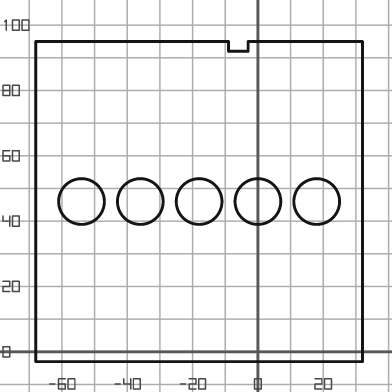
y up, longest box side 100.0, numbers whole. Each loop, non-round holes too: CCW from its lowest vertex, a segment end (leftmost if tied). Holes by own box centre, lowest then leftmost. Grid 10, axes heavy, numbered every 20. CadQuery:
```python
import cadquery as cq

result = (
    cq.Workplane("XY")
    .moveTo(-68.0, -3.0)
    .lineTo(32.0, -3.0)
    .lineTo(32.0, 95.0)
    .lineTo(-3.0, 95.0)
    .lineTo(-3.0, 92.0)
    .lineTo(-9.0, 92.0)
    .lineTo(-9.0, 95.0)
    .lineTo(-68.0, 95.0)
    .close()
    .moveTo(-54.0, 46.0)
    .circle(7.0)
    .moveTo(-36.0, 46.0)
    .circle(7.0)
    .moveTo(-18.0, 46.0)
    .circle(7.0)
    .moveTo(0.0, 46.0)
    .circle(7.0)
    .moveTo(18.0, 46.0)
    .circle(7.0)
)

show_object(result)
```